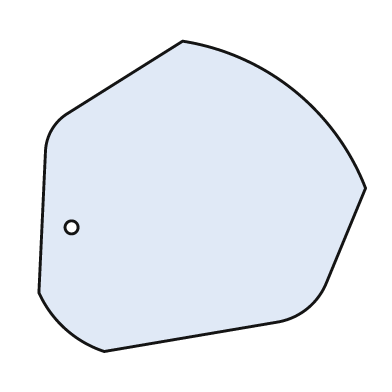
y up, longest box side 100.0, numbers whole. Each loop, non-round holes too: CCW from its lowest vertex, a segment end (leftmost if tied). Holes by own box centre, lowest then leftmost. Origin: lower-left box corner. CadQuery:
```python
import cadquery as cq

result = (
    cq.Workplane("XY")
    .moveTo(20.0, 0.0)
    .lineTo(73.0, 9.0)
    .threePointArc((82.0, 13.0), (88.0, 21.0))
    .lineTo(100.0, 50.0)
    .threePointArc((78.0, 80.0), (44.0, 95.0))
    .lineTo(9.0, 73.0)
    .threePointArc((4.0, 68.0), (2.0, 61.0))
    .lineTo(0.0, 18.0)
    .threePointArc((8.0, 7.0), (20.0, 0.0))
    .close()
    .moveTo(10.0, 38.0)
    .circle(2.0)
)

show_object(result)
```